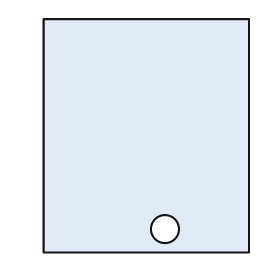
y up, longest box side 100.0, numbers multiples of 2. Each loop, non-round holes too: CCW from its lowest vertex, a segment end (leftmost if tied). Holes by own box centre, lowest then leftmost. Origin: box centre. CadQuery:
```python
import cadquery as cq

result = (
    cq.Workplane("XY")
    .moveTo(-44.0, -50.0)
    .lineTo(44.0, -50.0)
    .lineTo(44.0, 50.0)
    .lineTo(-44.0, 50.0)
    .close()
    .moveTo(8.0, -40.0)
    .circle(6.0)
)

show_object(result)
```